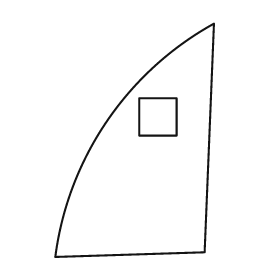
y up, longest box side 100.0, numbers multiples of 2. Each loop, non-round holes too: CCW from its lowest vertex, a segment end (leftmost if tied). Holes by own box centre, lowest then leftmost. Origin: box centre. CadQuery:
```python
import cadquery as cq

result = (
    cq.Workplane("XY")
    .moveTo(-34.0, -50.0)
    .lineTo(30.0, -48.0)
    .lineTo(34.0, 50.0)
    .threePointArc((-12.0, 8.0), (-34.0, -50.0))
    .close()
    .moveTo(2.0, 2.0)
    .lineTo(18.0, 2.0)
    .lineTo(18.0, 18.0)
    .lineTo(2.0, 18.0)
    .close()
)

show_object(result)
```